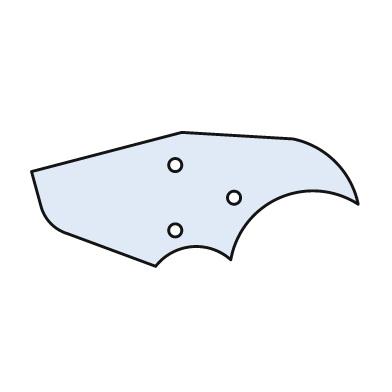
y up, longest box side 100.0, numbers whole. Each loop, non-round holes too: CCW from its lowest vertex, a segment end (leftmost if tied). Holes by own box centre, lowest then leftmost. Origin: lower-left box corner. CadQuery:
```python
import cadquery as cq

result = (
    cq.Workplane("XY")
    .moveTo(38.0, 0.0)
    .threePointArc((49.0, 6.0), (61.0, 2.0))
    .threePointArc((76.0, 21.0), (100.0, 19.0))
    .threePointArc((93.0, 32.0), (80.0, 39.0))
    .lineTo(46.0, 41.0)
    .lineTo(0.0, 29.0)
    .lineTo(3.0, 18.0)
    .threePointArc((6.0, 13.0), (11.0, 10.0))
    .close()
    .moveTo(44.0, 11.0)
    .circle(2.0)
    .moveTo(62.0, 21.0)
    .circle(2.0)
    .moveTo(44.0, 31.0)
    .circle(2.0)
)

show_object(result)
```